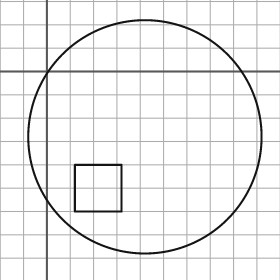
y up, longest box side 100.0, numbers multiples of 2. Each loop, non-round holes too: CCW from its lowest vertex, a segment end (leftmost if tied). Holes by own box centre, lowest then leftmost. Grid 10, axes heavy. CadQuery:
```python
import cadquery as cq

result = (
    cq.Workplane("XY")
    .moveTo(42.0, -28.0)
    .circle(50.0)
    .moveTo(12.0, -60.0)
    .lineTo(32.0, -60.0)
    .lineTo(32.0, -40.0)
    .lineTo(12.0, -40.0)
    .close()
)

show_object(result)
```